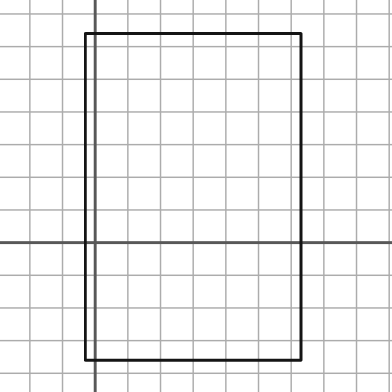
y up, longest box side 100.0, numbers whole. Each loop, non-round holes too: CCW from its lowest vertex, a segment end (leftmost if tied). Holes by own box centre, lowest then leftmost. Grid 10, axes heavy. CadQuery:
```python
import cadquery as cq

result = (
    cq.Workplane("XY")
    .moveTo(-3.0, -36.0)
    .lineTo(63.0, -36.0)
    .lineTo(63.0, 64.0)
    .lineTo(-3.0, 64.0)
    .close()
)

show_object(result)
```